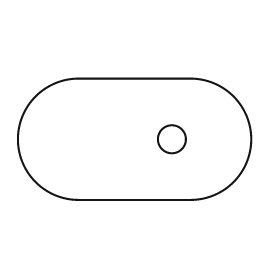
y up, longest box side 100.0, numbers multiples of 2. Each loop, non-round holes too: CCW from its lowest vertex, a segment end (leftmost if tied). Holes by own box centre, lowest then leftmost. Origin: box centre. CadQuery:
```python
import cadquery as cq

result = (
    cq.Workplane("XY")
    .moveTo(-24.0, -26.0)
    .lineTo(24.0, -26.0)
    .threePointArc((50.0, 0.0), (24.0, 26.0))
    .lineTo(-24.0, 26.0)
    .threePointArc((-50.0, 0.0), (-24.0, -26.0))
    .close()
    .moveTo(16.0, 0.0)
    .circle(6.0)
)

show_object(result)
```